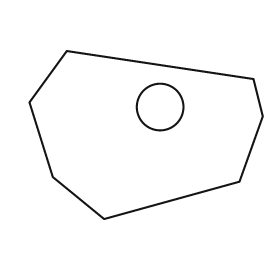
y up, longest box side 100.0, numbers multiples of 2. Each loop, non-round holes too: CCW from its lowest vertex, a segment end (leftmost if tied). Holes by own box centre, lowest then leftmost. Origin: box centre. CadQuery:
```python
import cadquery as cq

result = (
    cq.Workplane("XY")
    .moveTo(-18.0, -36.0)
    .lineTo(40.0, -20.0)
    .lineTo(50.0, 8.0)
    .lineTo(46.0, 24.0)
    .lineTo(-34.0, 36.0)
    .lineTo(-50.0, 14.0)
    .lineTo(-40.0, -18.0)
    .close()
    .moveTo(6.0, 12.0)
    .circle(10.0)
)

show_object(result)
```